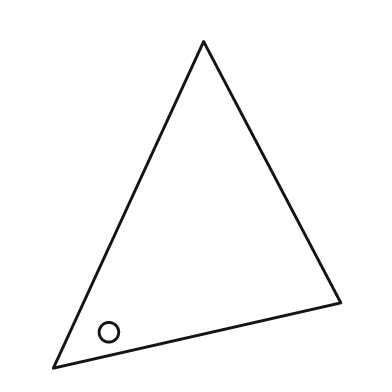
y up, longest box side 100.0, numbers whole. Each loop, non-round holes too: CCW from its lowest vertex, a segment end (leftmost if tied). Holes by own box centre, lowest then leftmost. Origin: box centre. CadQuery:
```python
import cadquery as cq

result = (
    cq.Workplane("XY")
    .moveTo(-44.0, -50.0)
    .lineTo(44.0, -30.0)
    .lineTo(2.0, 50.0)
    .close()
    .moveTo(-27.0, -39.0)
    .circle(3.0)
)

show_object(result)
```